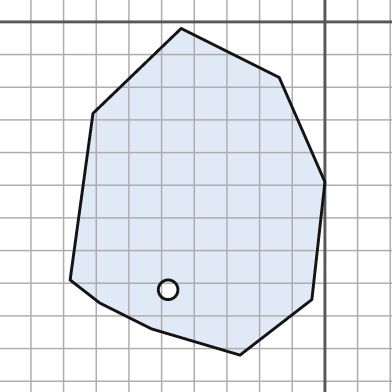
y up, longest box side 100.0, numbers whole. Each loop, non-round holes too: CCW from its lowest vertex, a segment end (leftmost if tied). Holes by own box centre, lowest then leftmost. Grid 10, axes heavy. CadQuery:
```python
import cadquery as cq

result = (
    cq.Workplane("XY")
    .moveTo(-26.0, -102.0)
    .lineTo(-4.0, -85.0)
    .lineTo(0.0, -49.0)
    .lineTo(-14.0, -17.0)
    .lineTo(-44.0, -2.0)
    .lineTo(-71.0, -28.0)
    .lineTo(-78.0, -79.0)
    .lineTo(-69.0, -86.0)
    .lineTo(-53.0, -94.0)
    .close()
    .moveTo(-48.0, -82.0)
    .circle(3.0)
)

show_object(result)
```